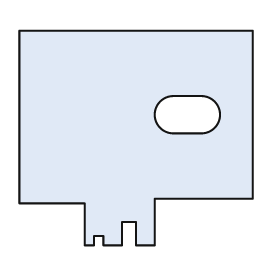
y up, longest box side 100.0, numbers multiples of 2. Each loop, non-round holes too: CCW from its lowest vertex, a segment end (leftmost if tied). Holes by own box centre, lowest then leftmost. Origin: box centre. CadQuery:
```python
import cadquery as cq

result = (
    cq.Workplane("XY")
    .moveTo(-22.0, -46.0)
    .lineTo(-18.0, -46.0)
    .lineTo(-18.0, -42.0)
    .lineTo(-14.0, -42.0)
    .lineTo(-14.0, -46.0)
    .lineTo(-6.0, -46.0)
    .lineTo(-6.0, -36.0)
    .lineTo(0.0, -36.0)
    .lineTo(0.0, -46.0)
    .lineTo(8.0, -46.0)
    .lineTo(8.0, -26.0)
    .lineTo(50.0, -26.0)
    .lineTo(50.0, 46.0)
    .lineTo(-50.0, 46.0)
    .lineTo(-50.0, -28.0)
    .lineTo(-22.0, -28.0)
    .close()
    .moveTo(16.0, 2.0)
    .lineTo(28.0, 2.0)
    .threePointArc((36.0, 10.0), (28.0, 18.0))
    .lineTo(16.0, 18.0)
    .threePointArc((8.0, 10.0), (16.0, 2.0))
    .close()
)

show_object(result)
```